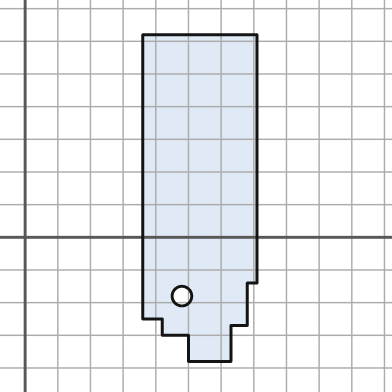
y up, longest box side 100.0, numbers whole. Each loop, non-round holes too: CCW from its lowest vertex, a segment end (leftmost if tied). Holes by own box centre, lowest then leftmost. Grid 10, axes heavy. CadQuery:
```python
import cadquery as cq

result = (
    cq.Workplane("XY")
    .moveTo(50.0, -38.0)
    .lineTo(63.0, -38.0)
    .lineTo(63.0, -27.0)
    .lineTo(68.0, -27.0)
    .lineTo(68.0, -14.0)
    .lineTo(71.0, -14.0)
    .lineTo(71.0, 62.0)
    .lineTo(36.0, 62.0)
    .lineTo(36.0, -25.0)
    .lineTo(42.0, -25.0)
    .lineTo(42.0, -30.0)
    .lineTo(50.0, -30.0)
    .close()
    .moveTo(48.0, -18.0)
    .circle(3.0)
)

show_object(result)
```